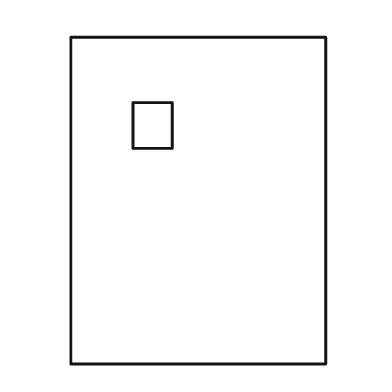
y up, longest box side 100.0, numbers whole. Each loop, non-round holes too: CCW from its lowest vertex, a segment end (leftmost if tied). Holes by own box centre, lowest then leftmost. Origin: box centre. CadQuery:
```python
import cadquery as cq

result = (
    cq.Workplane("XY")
    .moveTo(-39.0, -50.0)
    .lineTo(39.0, -50.0)
    .lineTo(39.0, 50.0)
    .lineTo(-39.0, 50.0)
    .close()
    .moveTo(-20.0, 16.0)
    .lineTo(-8.0, 16.0)
    .lineTo(-8.0, 30.0)
    .lineTo(-20.0, 30.0)
    .close()
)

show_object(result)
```